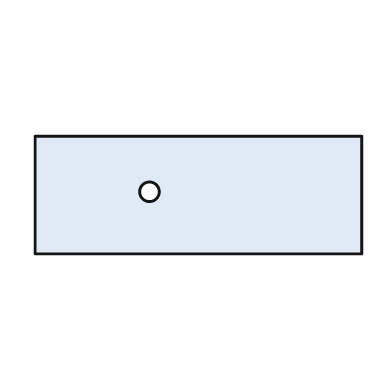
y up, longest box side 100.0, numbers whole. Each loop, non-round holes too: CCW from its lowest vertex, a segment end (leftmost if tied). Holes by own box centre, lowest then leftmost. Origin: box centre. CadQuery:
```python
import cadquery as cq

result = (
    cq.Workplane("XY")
    .moveTo(-50.0, -18.0)
    .lineTo(50.0, -18.0)
    .lineTo(50.0, 18.0)
    .lineTo(-50.0, 18.0)
    .close()
    .moveTo(-15.0, 1.0)
    .circle(3.0)
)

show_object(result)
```